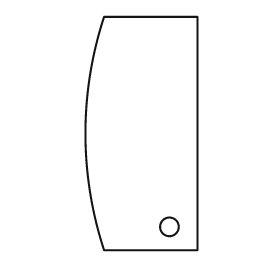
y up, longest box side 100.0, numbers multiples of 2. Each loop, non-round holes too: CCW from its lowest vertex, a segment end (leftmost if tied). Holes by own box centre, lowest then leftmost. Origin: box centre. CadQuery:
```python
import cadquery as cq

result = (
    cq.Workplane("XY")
    .moveTo(-16.0, -50.0)
    .lineTo(24.0, -50.0)
    .lineTo(24.0, 50.0)
    .lineTo(-16.0, 50.0)
    .threePointArc((-24.0, 0.0), (-16.0, -50.0))
    .close()
    .moveTo(12.0, -40.0)
    .circle(4.0)
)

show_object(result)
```